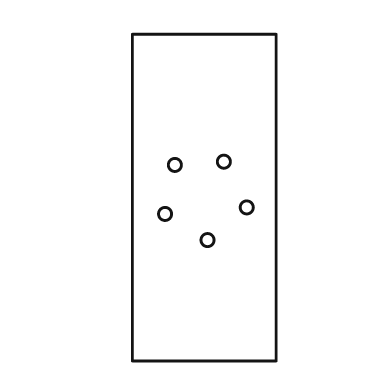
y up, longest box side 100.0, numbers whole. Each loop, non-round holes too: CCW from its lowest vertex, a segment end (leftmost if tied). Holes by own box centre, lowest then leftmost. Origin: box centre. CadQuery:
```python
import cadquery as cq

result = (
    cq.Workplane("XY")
    .moveTo(-22.0, -50.0)
    .lineTo(22.0, -50.0)
    .lineTo(22.0, 50.0)
    .lineTo(-22.0, 50.0)
    .close()
    .moveTo(1.0, -13.0)
    .circle(2.0)
    .moveTo(-12.0, -5.0)
    .circle(2.0)
    .moveTo(13.0, -3.0)
    .circle(2.0)
    .moveTo(-9.0, 10.0)
    .circle(2.0)
    .moveTo(6.0, 11.0)
    .circle(2.0)
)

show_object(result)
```